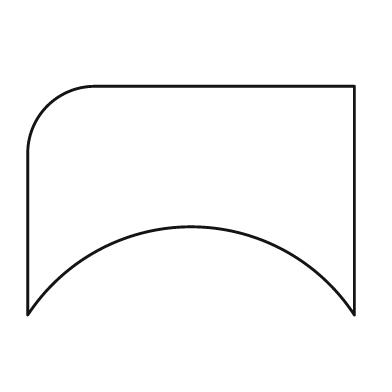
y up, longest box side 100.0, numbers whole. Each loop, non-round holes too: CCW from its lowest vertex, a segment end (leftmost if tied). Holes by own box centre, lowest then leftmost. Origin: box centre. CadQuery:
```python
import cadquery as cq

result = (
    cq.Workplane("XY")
    .moveTo(-50.0, -35.0)
    .threePointArc((0.0, -8.0), (50.0, -35.0))
    .lineTo(50.0, 35.0)
    .lineTo(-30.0, 35.0)
    .threePointArc((-44.0, 29.0), (-50.0, 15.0))
    .close()
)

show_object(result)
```